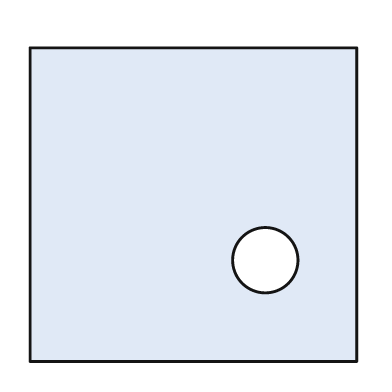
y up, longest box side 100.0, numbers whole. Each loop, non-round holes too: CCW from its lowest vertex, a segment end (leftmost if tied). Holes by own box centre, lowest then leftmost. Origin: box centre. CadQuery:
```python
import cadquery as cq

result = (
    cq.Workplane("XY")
    .moveTo(-50.0, -48.0)
    .lineTo(50.0, -48.0)
    .lineTo(50.0, 48.0)
    .lineTo(-50.0, 48.0)
    .close()
    .moveTo(22.0, -17.0)
    .circle(10.0)
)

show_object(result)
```